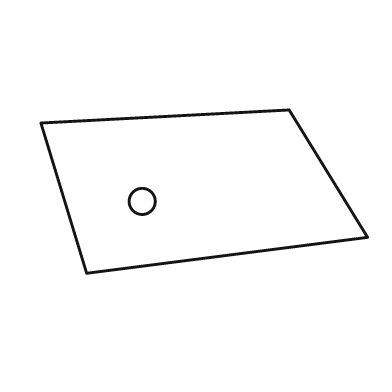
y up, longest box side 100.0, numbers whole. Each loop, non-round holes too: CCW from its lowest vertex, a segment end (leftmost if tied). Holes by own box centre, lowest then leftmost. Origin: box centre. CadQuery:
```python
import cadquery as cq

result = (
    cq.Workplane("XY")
    .moveTo(-36.0, -25.0)
    .lineTo(50.0, -14.0)
    .lineTo(26.0, 25.0)
    .lineTo(-50.0, 21.0)
    .close()
    .moveTo(-19.0, -3.0)
    .circle(4.0)
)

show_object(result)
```